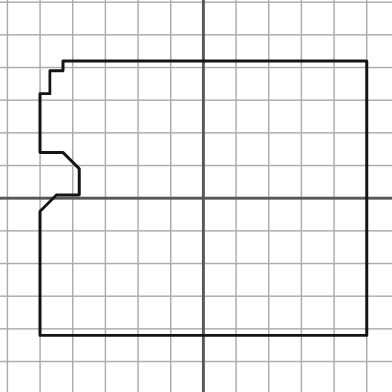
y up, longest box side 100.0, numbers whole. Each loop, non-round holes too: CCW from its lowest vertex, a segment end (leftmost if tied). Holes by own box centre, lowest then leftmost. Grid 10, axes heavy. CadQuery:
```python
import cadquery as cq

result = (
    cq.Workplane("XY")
    .moveTo(-50.0, -42.0)
    .lineTo(50.0, -42.0)
    .lineTo(50.0, 42.0)
    .lineTo(-43.0, 42.0)
    .lineTo(-43.0, 39.0)
    .lineTo(-47.0, 39.0)
    .lineTo(-47.0, 32.0)
    .lineTo(-50.0, 32.0)
    .lineTo(-50.0, 14.0)
    .lineTo(-43.0, 14.0)
    .lineTo(-38.0, 9.0)
    .lineTo(-38.0, 1.0)
    .lineTo(-45.0, 1.0)
    .lineTo(-50.0, -4.0)
    .close()
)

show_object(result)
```